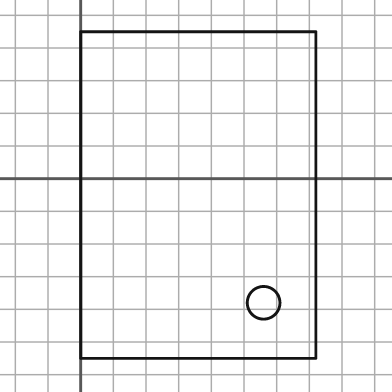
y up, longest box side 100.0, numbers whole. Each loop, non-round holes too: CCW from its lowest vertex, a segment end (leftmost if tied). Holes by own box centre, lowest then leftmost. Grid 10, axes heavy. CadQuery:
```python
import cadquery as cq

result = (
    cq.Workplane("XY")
    .moveTo(0.0, -55.0)
    .lineTo(72.0, -55.0)
    .lineTo(72.0, 45.0)
    .lineTo(0.0, 45.0)
    .close()
    .moveTo(56.0, -38.0)
    .circle(5.0)
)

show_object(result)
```